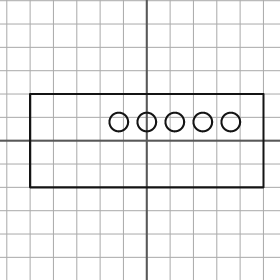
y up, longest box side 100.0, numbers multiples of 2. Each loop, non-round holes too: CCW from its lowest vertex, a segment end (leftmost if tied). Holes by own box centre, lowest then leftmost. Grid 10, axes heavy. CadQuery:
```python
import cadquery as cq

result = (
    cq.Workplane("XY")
    .moveTo(-50.0, -20.0)
    .lineTo(50.0, -20.0)
    .lineTo(50.0, 20.0)
    .lineTo(-50.0, 20.0)
    .close()
    .moveTo(-12.0, 8.0)
    .circle(4.0)
    .moveTo(0.0, 8.0)
    .circle(4.0)
    .moveTo(12.0, 8.0)
    .circle(4.0)
    .moveTo(24.0, 8.0)
    .circle(4.0)
    .moveTo(36.0, 8.0)
    .circle(4.0)
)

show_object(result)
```